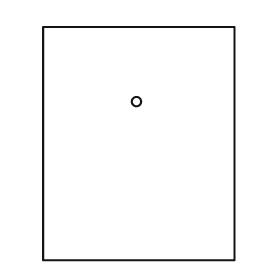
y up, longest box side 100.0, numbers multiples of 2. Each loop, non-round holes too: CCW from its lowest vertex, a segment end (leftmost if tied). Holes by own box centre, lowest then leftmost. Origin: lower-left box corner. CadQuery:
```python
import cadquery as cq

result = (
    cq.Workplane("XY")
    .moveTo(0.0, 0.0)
    .lineTo(82.0, 0.0)
    .lineTo(82.0, 100.0)
    .lineTo(0.0, 100.0)
    .close()
    .moveTo(40.0, 68.0)
    .circle(2.0)
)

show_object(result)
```